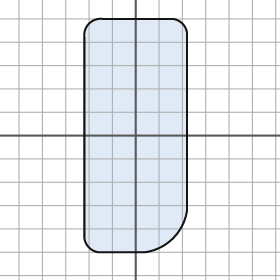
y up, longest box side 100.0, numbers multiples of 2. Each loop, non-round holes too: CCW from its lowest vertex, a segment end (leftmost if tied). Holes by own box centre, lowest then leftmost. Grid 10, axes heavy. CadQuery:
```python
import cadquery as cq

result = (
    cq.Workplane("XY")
    .moveTo(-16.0, -50.0)
    .lineTo(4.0, -50.0)
    .threePointArc((16.0, -44.0), (22.0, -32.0))
    .lineTo(22.0, 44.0)
    .threePointArc((20.0, 48.0), (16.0, 50.0))
    .lineTo(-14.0, 50.0)
    .threePointArc((-20.0, 48.0), (-22.0, 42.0))
    .lineTo(-22.0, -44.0)
    .threePointArc((-20.0, -48.0), (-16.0, -50.0))
    .close()
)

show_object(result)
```